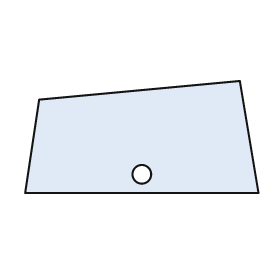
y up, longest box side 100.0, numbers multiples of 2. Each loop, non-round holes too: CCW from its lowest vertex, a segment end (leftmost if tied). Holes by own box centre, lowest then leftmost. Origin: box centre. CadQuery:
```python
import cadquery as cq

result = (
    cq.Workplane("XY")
    .moveTo(-50.0, -24.0)
    .lineTo(50.0, -24.0)
    .lineTo(42.0, 24.0)
    .lineTo(-44.0, 16.0)
    .close()
    .moveTo(0.0, -16.0)
    .circle(4.0)
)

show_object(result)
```